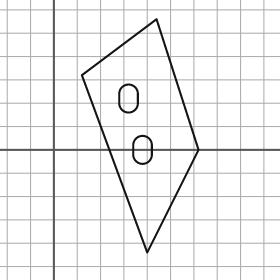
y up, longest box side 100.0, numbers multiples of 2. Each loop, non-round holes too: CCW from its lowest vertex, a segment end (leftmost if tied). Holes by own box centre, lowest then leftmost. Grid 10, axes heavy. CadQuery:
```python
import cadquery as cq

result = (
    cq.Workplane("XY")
    .moveTo(40.0, -44.0)
    .lineTo(62.0, 0.0)
    .lineTo(44.0, 56.0)
    .lineTo(12.0, 32.0)
    .close()
    .moveTo(34.0, -2.0)
    .threePointArc((38.0, -6.0), (42.0, -2.0))
    .lineTo(42.0, 2.0)
    .threePointArc((38.0, 6.0), (34.0, 2.0))
    .close()
    .moveTo(28.0, 20.0)
    .threePointArc((32.0, 16.0), (36.0, 20.0))
    .lineTo(36.0, 24.0)
    .threePointArc((32.0, 28.0), (28.0, 24.0))
    .close()
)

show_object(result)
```